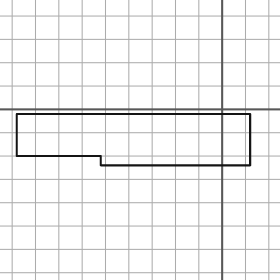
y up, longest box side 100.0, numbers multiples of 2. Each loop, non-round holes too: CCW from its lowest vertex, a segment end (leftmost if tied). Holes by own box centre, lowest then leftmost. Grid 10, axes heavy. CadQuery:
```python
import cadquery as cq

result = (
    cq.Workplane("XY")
    .moveTo(-52.0, -24.0)
    .lineTo(12.0, -24.0)
    .lineTo(12.0, -2.0)
    .lineTo(-88.0, -2.0)
    .lineTo(-88.0, -20.0)
    .lineTo(-52.0, -20.0)
    .close()
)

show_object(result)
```